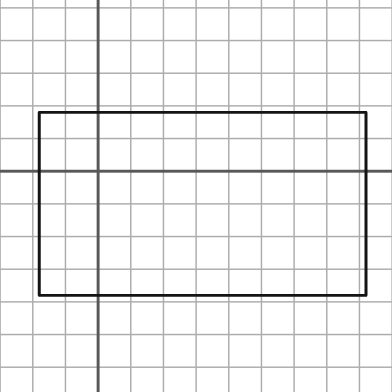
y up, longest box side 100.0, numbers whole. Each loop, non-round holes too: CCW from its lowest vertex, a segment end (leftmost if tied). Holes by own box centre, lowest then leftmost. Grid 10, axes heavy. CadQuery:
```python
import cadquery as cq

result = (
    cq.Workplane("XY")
    .moveTo(-18.0, -38.0)
    .lineTo(82.0, -38.0)
    .lineTo(82.0, 18.0)
    .lineTo(-18.0, 18.0)
    .close()
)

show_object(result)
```